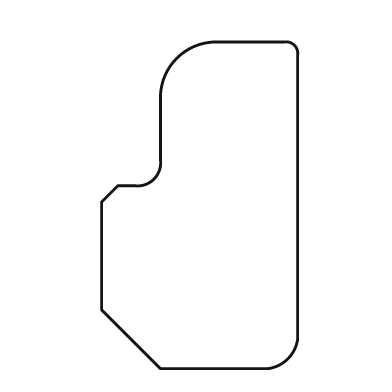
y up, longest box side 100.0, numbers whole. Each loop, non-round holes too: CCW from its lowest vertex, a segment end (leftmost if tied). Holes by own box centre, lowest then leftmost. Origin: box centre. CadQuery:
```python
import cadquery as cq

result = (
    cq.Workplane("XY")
    .moveTo(-12.0, -50.0)
    .lineTo(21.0, -50.0)
    .threePointArc((27.0, -47.0), (30.0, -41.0))
    .lineTo(30.0, 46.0)
    .threePointArc((29.0, 49.0), (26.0, 50.0))
    .lineTo(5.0, 50.0)
    .threePointArc((-7.0, 45.0), (-12.0, 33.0))
    .lineTo(-12.0, 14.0)
    .threePointArc((-14.0, 8.0), (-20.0, 6.0))
    .lineTo(-25.0, 6.0)
    .lineTo(-30.0, 1.0)
    .lineTo(-30.0, -32.0)
    .close()
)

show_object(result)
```